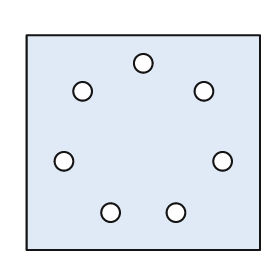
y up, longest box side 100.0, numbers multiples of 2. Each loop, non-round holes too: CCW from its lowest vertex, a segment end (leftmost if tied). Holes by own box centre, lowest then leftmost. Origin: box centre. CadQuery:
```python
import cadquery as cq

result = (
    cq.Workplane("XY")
    .moveTo(-50.0, -46.0)
    .lineTo(50.0, -46.0)
    .lineTo(50.0, 46.0)
    .lineTo(-50.0, 46.0)
    .close()
    .moveTo(-14.0, -30.0)
    .circle(4.0)
    .moveTo(14.0, -30.0)
    .circle(4.0)
    .moveTo(-34.0, -8.0)
    .circle(4.0)
    .moveTo(34.0, -8.0)
    .circle(4.0)
    .moveTo(-26.0, 22.0)
    .circle(4.0)
    .moveTo(26.0, 22.0)
    .circle(4.0)
    .moveTo(0.0, 34.0)
    .circle(4.0)
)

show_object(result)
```